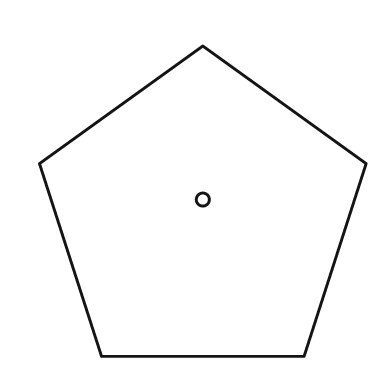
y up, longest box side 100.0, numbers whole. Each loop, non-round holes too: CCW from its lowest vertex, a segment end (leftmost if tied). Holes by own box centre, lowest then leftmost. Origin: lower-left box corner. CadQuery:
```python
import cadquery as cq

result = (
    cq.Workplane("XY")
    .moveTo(19.0, 0.0)
    .lineTo(81.0, 0.0)
    .lineTo(100.0, 59.0)
    .lineTo(50.0, 95.0)
    .lineTo(0.0, 59.0)
    .close()
    .moveTo(50.0, 48.0)
    .circle(2.0)
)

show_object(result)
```